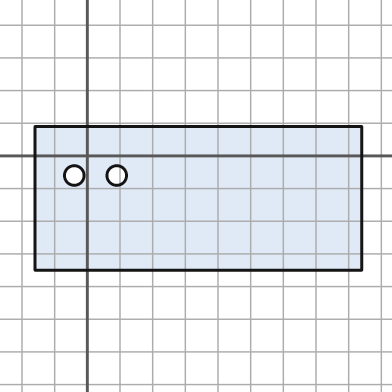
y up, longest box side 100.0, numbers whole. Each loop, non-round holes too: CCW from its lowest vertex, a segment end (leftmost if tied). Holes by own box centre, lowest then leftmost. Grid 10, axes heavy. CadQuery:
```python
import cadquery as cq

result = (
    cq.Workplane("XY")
    .moveTo(-16.0, -35.0)
    .lineTo(84.0, -35.0)
    .lineTo(84.0, 9.0)
    .lineTo(-16.0, 9.0)
    .close()
    .moveTo(-4.0, -6.0)
    .circle(3.0)
    .moveTo(9.0, -6.0)
    .circle(3.0)
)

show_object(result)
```